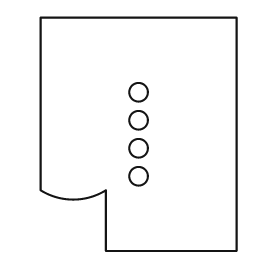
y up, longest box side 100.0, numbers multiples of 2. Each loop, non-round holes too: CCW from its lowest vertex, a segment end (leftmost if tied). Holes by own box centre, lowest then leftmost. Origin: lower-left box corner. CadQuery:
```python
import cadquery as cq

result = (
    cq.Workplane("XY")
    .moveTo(28.0, 0.0)
    .lineTo(84.0, 0.0)
    .lineTo(84.0, 100.0)
    .lineTo(0.0, 100.0)
    .lineTo(0.0, 26.0)
    .threePointArc((14.0, 22.0), (28.0, 26.0))
    .close()
    .moveTo(42.0, 32.0)
    .circle(4.0)
    .moveTo(42.0, 44.0)
    .circle(4.0)
    .moveTo(42.0, 56.0)
    .circle(4.0)
    .moveTo(42.0, 68.0)
    .circle(4.0)
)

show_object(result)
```